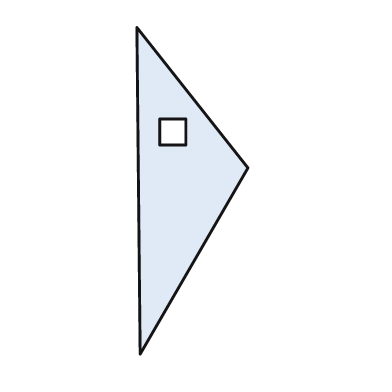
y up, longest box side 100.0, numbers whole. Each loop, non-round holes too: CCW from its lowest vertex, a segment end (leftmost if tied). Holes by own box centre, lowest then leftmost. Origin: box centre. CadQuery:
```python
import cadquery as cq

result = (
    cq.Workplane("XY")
    .moveTo(-16.0, -50.0)
    .lineTo(17.0, 7.0)
    .lineTo(-17.0, 50.0)
    .close()
    .moveTo(-10.0, 14.0)
    .lineTo(-2.0, 14.0)
    .lineTo(-2.0, 22.0)
    .lineTo(-10.0, 22.0)
    .close()
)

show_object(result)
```